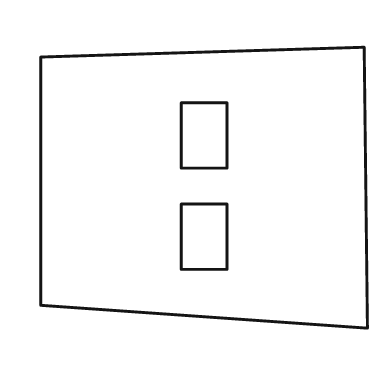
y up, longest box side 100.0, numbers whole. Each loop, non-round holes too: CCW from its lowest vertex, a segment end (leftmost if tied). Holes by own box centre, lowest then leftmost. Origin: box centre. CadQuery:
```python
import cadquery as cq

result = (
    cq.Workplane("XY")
    .moveTo(50.0, -43.0)
    .lineTo(49.0, 43.0)
    .lineTo(-50.0, 40.0)
    .lineTo(-50.0, -36.0)
    .close()
    .moveTo(-7.0, -25.0)
    .lineTo(7.0, -25.0)
    .lineTo(7.0, -5.0)
    .lineTo(-7.0, -5.0)
    .close()
    .moveTo(-7.0, 6.0)
    .lineTo(7.0, 6.0)
    .lineTo(7.0, 26.0)
    .lineTo(-7.0, 26.0)
    .close()
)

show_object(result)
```